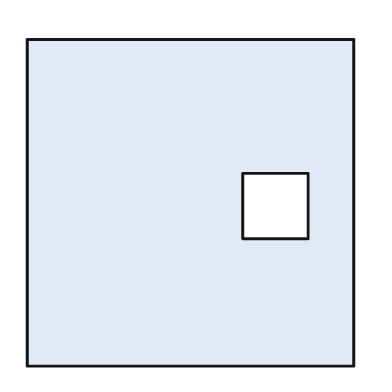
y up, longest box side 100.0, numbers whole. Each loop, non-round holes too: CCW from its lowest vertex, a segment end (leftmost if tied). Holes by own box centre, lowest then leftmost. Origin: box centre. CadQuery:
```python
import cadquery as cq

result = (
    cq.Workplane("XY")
    .moveTo(-50.0, -50.0)
    .lineTo(50.0, -50.0)
    .lineTo(50.0, 50.0)
    .lineTo(-50.0, 50.0)
    .close()
    .moveTo(16.0, -11.0)
    .lineTo(36.0, -11.0)
    .lineTo(36.0, 9.0)
    .lineTo(16.0, 9.0)
    .close()
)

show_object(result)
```